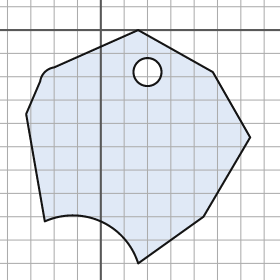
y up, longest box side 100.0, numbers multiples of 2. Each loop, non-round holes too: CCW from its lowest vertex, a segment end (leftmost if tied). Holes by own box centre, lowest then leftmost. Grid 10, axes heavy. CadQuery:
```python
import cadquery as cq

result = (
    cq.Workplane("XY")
    .moveTo(16.0, -100.0)
    .lineTo(44.0, -80.0)
    .lineTo(64.0, -46.0)
    .lineTo(48.0, -18.0)
    .lineTo(16.0, 0.0)
    .lineTo(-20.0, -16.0)
    .threePointArc((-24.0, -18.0), (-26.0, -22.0))
    .lineTo(-32.0, -36.0)
    .lineTo(-24.0, -82.0)
    .threePointArc((0.0, -82.0), (16.0, -100.0))
    .close()
    .moveTo(20.0, -18.0)
    .circle(6.0)
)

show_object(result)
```